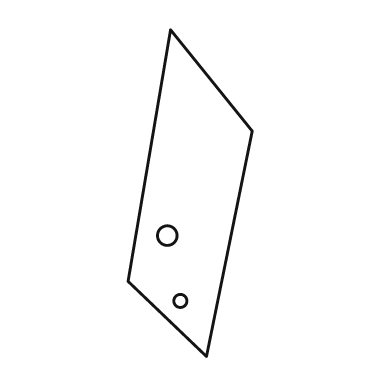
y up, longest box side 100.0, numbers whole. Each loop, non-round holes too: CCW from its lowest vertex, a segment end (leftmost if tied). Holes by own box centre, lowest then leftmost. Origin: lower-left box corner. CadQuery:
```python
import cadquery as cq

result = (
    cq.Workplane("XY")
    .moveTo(24.0, 0.0)
    .lineTo(38.0, 69.0)
    .lineTo(13.0, 100.0)
    .lineTo(0.0, 23.0)
    .close()
    .moveTo(16.0, 17.0)
    .circle(2.0)
    .moveTo(12.0, 37.0)
    .circle(3.0)
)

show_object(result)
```